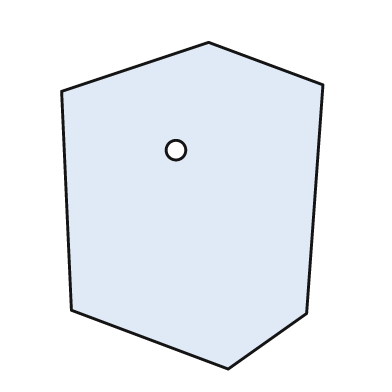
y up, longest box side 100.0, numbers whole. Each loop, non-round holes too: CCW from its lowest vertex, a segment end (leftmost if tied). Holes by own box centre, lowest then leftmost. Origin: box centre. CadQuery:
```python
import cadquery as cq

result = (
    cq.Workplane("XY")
    .moveTo(11.0, -50.0)
    .lineTo(35.0, -33.0)
    .lineTo(40.0, 37.0)
    .lineTo(5.0, 50.0)
    .lineTo(-40.0, 35.0)
    .lineTo(-37.0, -32.0)
    .close()
    .moveTo(-5.0, 17.0)
    .circle(3.0)
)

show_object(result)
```